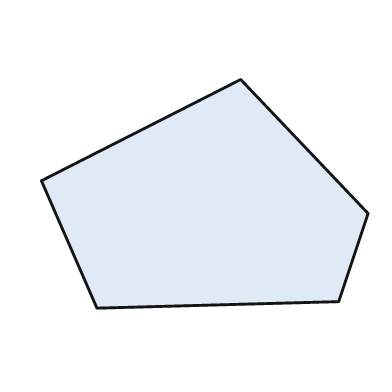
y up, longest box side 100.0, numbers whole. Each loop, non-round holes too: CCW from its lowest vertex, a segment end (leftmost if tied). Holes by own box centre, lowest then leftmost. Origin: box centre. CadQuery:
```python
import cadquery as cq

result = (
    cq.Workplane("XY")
    .moveTo(-33.0, -35.0)
    .lineTo(41.0, -33.0)
    .lineTo(50.0, -6.0)
    .lineTo(11.0, 35.0)
    .lineTo(-50.0, 4.0)
    .close()
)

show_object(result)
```